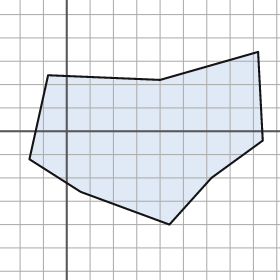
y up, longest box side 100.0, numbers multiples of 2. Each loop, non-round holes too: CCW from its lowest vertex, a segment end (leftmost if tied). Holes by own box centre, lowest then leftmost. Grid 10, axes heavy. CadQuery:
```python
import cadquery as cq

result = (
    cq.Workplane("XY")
    .moveTo(44.0, -40.0)
    .lineTo(62.0, -20.0)
    .lineTo(84.0, -4.0)
    .lineTo(82.0, 34.0)
    .lineTo(40.0, 22.0)
    .lineTo(-8.0, 24.0)
    .lineTo(-16.0, -12.0)
    .lineTo(6.0, -26.0)
    .close()
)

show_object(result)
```